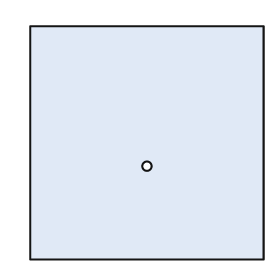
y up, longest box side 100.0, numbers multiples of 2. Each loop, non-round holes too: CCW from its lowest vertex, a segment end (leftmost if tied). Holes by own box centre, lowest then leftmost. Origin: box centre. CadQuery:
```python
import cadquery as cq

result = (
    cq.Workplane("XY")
    .moveTo(-50.0, -50.0)
    .lineTo(50.0, -50.0)
    .lineTo(50.0, 50.0)
    .lineTo(-50.0, 50.0)
    .close()
    .moveTo(0.0, -10.0)
    .circle(2.0)
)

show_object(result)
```